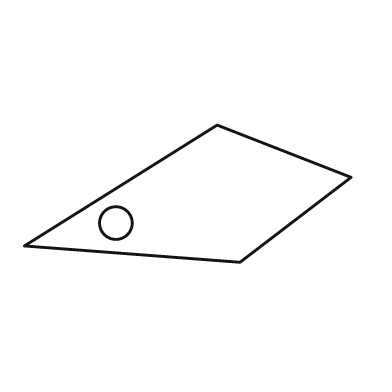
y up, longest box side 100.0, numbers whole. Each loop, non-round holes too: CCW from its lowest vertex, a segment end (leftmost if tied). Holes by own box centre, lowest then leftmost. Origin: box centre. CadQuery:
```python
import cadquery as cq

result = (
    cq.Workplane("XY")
    .moveTo(16.0, -21.0)
    .lineTo(50.0, 5.0)
    .lineTo(9.0, 21.0)
    .lineTo(-50.0, -16.0)
    .close()
    .moveTo(-22.0, -9.0)
    .circle(5.0)
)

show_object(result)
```